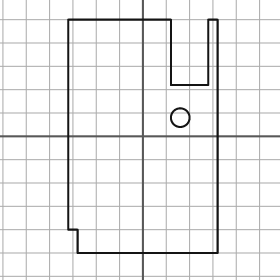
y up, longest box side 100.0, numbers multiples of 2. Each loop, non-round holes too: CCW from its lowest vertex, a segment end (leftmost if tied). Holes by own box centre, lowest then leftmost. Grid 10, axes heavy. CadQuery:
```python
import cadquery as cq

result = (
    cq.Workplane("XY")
    .moveTo(-28.0, -50.0)
    .lineTo(32.0, -50.0)
    .lineTo(32.0, 50.0)
    .lineTo(28.0, 50.0)
    .lineTo(28.0, 22.0)
    .lineTo(12.0, 22.0)
    .lineTo(12.0, 50.0)
    .lineTo(-32.0, 50.0)
    .lineTo(-32.0, -40.0)
    .lineTo(-28.0, -40.0)
    .close()
    .moveTo(16.0, 8.0)
    .circle(4.0)
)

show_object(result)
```